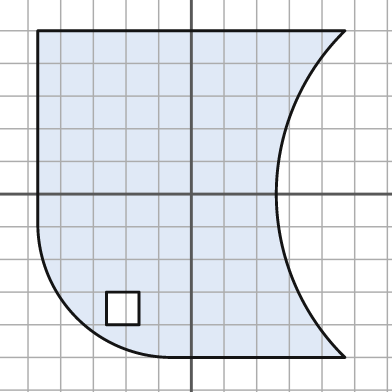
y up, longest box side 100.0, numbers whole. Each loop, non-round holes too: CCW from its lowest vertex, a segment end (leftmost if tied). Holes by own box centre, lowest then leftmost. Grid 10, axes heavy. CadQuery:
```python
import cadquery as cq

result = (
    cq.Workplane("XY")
    .moveTo(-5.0, -50.0)
    .lineTo(47.0, -50.0)
    .threePointArc((26.0, 0.0), (47.0, 50.0))
    .lineTo(-47.0, 50.0)
    .lineTo(-47.0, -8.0)
    .threePointArc((-35.0, -38.0), (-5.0, -50.0))
    .close()
    .moveTo(-26.0, -40.0)
    .lineTo(-16.0, -40.0)
    .lineTo(-16.0, -30.0)
    .lineTo(-26.0, -30.0)
    .close()
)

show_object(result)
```